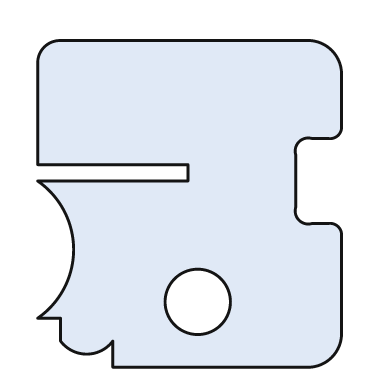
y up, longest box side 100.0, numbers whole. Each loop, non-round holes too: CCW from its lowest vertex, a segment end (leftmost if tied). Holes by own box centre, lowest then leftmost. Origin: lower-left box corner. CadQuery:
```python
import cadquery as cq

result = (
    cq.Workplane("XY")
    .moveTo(23.0, 0.0)
    .lineTo(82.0, 0.0)
    .threePointArc((90.0, 3.0), (93.0, 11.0))
    .lineTo(93.0, 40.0)
    .threePointArc((92.0, 43.0), (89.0, 44.0))
    .lineTo(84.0, 44.0)
    .threePointArc((80.0, 45.0), (79.0, 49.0))
    .lineTo(79.0, 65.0)
    .threePointArc((80.0, 69.0), (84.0, 70.0))
    .lineTo(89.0, 70.0)
    .threePointArc((92.0, 71.0), (93.0, 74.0))
    .lineTo(93.0, 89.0)
    .threePointArc((90.0, 97.0), (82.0, 100.0))
    .lineTo(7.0, 100.0)
    .threePointArc((2.0, 98.0), (0.0, 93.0))
    .lineTo(0.0, 62.0)
    .lineTo(46.0, 62.0)
    .lineTo(46.0, 57.0)
    .lineTo(0.0, 57.0)
    .threePointArc((11.0, 36.0), (0.0, 15.0))
    .lineTo(7.0, 15.0)
    .lineTo(7.0, 8.0)
    .threePointArc((15.0, 4.0), (23.0, 8.0))
    .close()
    .moveTo(49.0, 20.0)
    .circle(10.0)
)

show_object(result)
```